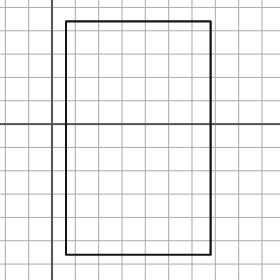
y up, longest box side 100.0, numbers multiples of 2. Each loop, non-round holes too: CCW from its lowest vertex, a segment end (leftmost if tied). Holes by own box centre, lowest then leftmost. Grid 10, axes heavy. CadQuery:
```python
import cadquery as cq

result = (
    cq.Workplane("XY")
    .moveTo(6.0, -56.0)
    .lineTo(68.0, -56.0)
    .lineTo(68.0, 44.0)
    .lineTo(6.0, 44.0)
    .close()
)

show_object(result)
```